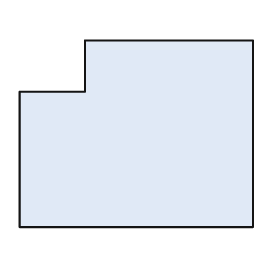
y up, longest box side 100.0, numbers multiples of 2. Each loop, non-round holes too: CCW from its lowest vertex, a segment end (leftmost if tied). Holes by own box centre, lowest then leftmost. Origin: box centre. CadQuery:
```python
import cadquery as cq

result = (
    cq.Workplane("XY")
    .moveTo(-50.0, -40.0)
    .lineTo(50.0, -40.0)
    .lineTo(50.0, 40.0)
    .lineTo(-22.0, 40.0)
    .lineTo(-22.0, 18.0)
    .lineTo(-50.0, 18.0)
    .close()
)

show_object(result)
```